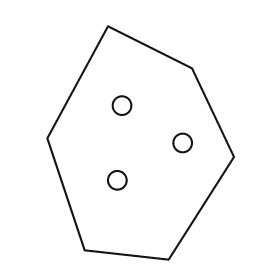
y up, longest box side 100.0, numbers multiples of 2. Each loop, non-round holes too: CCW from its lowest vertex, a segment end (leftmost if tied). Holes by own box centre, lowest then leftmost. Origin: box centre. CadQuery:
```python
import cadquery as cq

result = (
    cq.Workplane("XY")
    .moveTo(12.0, -50.0)
    .lineTo(40.0, -6.0)
    .lineTo(22.0, 32.0)
    .lineTo(-14.0, 50.0)
    .lineTo(-40.0, 2.0)
    .lineTo(-24.0, -46.0)
    .close()
    .moveTo(-10.0, -16.0)
    .circle(4.0)
    .moveTo(18.0, 0.0)
    .circle(4.0)
    .moveTo(-8.0, 16.0)
    .circle(4.0)
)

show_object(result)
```